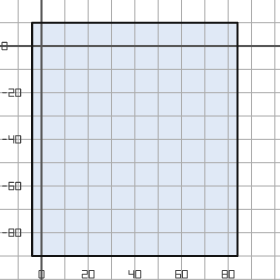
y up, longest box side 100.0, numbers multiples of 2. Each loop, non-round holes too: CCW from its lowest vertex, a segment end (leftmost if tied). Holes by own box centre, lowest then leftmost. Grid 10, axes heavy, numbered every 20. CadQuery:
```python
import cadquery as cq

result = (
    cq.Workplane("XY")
    .moveTo(-4.0, -90.0)
    .lineTo(84.0, -90.0)
    .lineTo(84.0, 10.0)
    .lineTo(-4.0, 10.0)
    .close()
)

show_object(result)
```